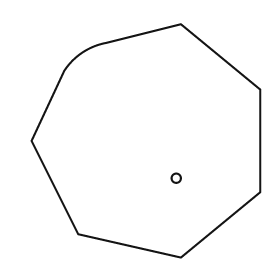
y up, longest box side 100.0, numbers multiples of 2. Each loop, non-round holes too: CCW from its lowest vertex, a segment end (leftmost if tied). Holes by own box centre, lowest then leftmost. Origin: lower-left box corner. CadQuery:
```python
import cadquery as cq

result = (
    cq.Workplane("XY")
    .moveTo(64.0, 0.0)
    .lineTo(98.0, 28.0)
    .lineTo(98.0, 72.0)
    .lineTo(64.0, 100.0)
    .lineTo(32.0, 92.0)
    .threePointArc((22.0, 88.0), (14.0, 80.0))
    .lineTo(0.0, 50.0)
    .lineTo(20.0, 10.0)
    .close()
    .moveTo(62.0, 34.0)
    .circle(2.0)
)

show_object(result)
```